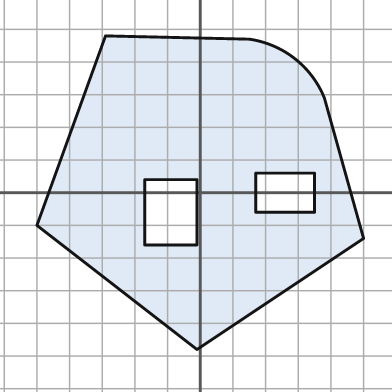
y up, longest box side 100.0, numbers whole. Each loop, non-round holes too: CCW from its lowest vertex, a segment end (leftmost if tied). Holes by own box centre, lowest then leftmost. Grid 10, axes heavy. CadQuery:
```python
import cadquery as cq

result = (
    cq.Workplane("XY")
    .moveTo(-1.0, -48.0)
    .lineTo(50.0, -14.0)
    .lineTo(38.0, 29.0)
    .threePointArc((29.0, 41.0), (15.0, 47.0))
    .lineTo(-29.0, 48.0)
    .lineTo(-50.0, -10.0)
    .close()
    .moveTo(-17.0, -16.0)
    .lineTo(-1.0, -16.0)
    .lineTo(-1.0, 4.0)
    .lineTo(-17.0, 4.0)
    .close()
    .moveTo(17.0, -6.0)
    .lineTo(35.0, -6.0)
    .lineTo(35.0, 6.0)
    .lineTo(17.0, 6.0)
    .close()
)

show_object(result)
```